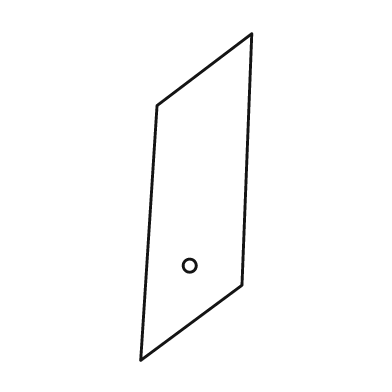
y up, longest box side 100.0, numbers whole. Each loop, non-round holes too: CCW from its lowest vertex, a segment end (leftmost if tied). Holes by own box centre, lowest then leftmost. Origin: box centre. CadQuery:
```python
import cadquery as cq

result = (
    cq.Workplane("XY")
    .moveTo(-17.0, -50.0)
    .lineTo(14.0, -27.0)
    .lineTo(17.0, 50.0)
    .lineTo(-12.0, 28.0)
    .close()
    .moveTo(-2.0, -21.0)
    .circle(2.0)
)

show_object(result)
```